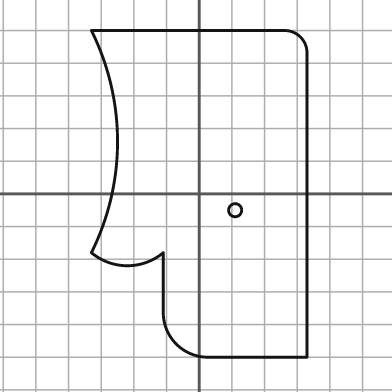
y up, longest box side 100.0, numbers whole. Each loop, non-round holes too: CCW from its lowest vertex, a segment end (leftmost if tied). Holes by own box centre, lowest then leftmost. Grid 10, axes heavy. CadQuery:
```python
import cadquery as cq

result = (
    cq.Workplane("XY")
    .moveTo(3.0, -50.0)
    .lineTo(33.0, -50.0)
    .lineTo(33.0, 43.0)
    .threePointArc((31.0, 48.0), (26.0, 50.0))
    .lineTo(-33.0, 50.0)
    .threePointArc((-25.0, 16.0), (-33.0, -18.0))
    .threePointArc((-22.0, -22.0), (-11.0, -18.0))
    .lineTo(-11.0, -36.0)
    .threePointArc((-7.0, -46.0), (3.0, -50.0))
    .close()
    .moveTo(11.0, -5.0)
    .circle(2.0)
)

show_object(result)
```